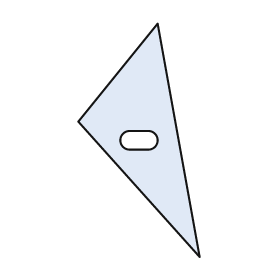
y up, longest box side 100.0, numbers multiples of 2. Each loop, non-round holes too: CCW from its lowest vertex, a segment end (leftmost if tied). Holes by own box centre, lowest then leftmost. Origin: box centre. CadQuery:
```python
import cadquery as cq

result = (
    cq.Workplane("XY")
    .moveTo(26.0, -50.0)
    .lineTo(8.0, 50.0)
    .lineTo(-26.0, 8.0)
    .close()
    .moveTo(-4.0, -4.0)
    .lineTo(4.0, -4.0)
    .threePointArc((8.0, 0.0), (4.0, 4.0))
    .lineTo(-4.0, 4.0)
    .threePointArc((-8.0, 0.0), (-4.0, -4.0))
    .close()
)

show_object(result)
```